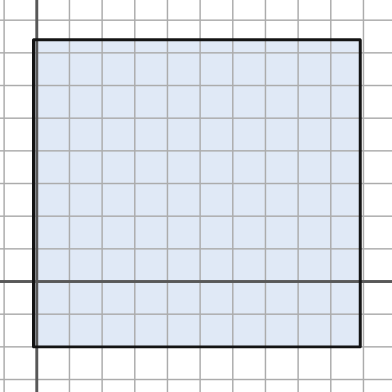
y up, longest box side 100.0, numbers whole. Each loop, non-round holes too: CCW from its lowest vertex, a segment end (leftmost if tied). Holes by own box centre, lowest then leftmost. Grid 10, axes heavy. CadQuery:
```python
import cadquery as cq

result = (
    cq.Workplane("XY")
    .moveTo(-1.0, -20.0)
    .lineTo(99.0, -20.0)
    .lineTo(99.0, 74.0)
    .lineTo(-1.0, 74.0)
    .close()
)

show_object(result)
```